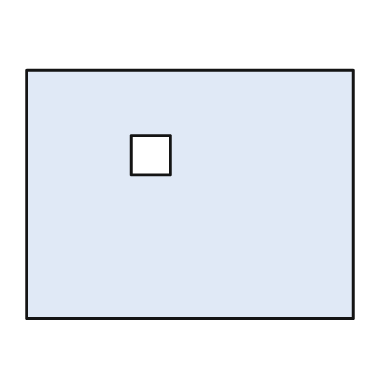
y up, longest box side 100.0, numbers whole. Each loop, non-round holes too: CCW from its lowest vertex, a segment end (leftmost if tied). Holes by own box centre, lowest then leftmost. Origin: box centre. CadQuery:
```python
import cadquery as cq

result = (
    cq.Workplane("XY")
    .moveTo(-50.0, -38.0)
    .lineTo(50.0, -38.0)
    .lineTo(50.0, 38.0)
    .lineTo(-50.0, 38.0)
    .close()
    .moveTo(-18.0, 6.0)
    .lineTo(-6.0, 6.0)
    .lineTo(-6.0, 18.0)
    .lineTo(-18.0, 18.0)
    .close()
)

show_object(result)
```